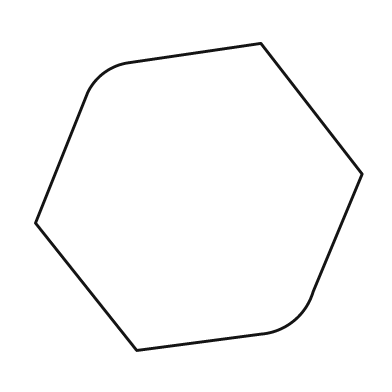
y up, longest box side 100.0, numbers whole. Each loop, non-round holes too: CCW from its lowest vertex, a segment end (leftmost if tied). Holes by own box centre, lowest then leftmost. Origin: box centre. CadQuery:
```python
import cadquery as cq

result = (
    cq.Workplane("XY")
    .moveTo(-19.0, -47.0)
    .lineTo(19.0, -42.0)
    .threePointArc((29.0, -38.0), (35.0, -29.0))
    .lineTo(50.0, 7.0)
    .lineTo(19.0, 47.0)
    .lineTo(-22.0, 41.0)
    .threePointArc((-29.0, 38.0), (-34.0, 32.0))
    .lineTo(-50.0, -8.0)
    .close()
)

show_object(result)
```